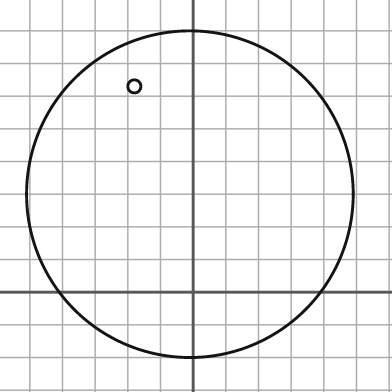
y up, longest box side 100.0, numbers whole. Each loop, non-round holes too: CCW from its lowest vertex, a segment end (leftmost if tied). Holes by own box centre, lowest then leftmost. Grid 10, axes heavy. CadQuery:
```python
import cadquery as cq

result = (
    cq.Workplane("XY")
    .moveTo(-1.0, 30.0)
    .circle(50.0)
    .moveTo(-18.0, 63.0)
    .circle(2.0)
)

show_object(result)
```